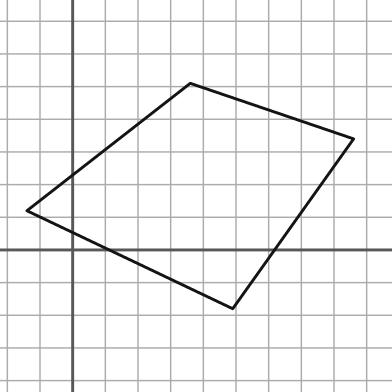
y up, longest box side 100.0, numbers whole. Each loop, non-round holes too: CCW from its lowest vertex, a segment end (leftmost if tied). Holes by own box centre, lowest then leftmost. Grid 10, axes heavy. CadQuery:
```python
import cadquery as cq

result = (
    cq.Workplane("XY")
    .moveTo(49.0, -18.0)
    .lineTo(86.0, 34.0)
    .lineTo(36.0, 51.0)
    .lineTo(-14.0, 12.0)
    .close()
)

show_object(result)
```